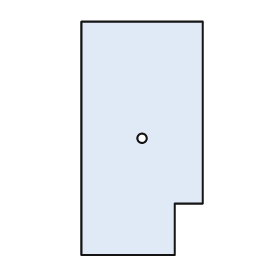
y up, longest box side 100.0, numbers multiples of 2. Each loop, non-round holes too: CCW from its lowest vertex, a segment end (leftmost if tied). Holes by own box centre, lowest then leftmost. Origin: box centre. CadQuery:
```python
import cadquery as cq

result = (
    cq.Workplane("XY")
    .moveTo(-26.0, -50.0)
    .lineTo(14.0, -50.0)
    .lineTo(14.0, -28.0)
    .lineTo(26.0, -28.0)
    .lineTo(26.0, 50.0)
    .lineTo(-26.0, 50.0)
    .close()
    .moveTo(0.0, 0.0)
    .circle(2.0)
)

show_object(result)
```